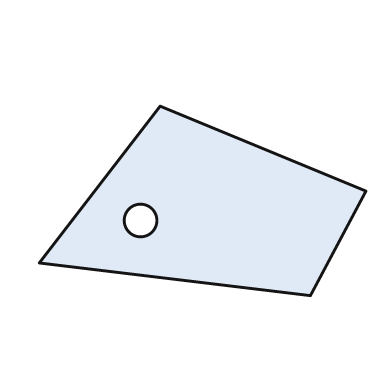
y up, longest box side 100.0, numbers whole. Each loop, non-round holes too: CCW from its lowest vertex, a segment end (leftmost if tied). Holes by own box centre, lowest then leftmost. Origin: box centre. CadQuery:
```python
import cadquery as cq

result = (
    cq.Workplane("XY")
    .moveTo(33.0, -29.0)
    .lineTo(50.0, 3.0)
    .lineTo(-13.0, 29.0)
    .lineTo(-50.0, -19.0)
    .close()
    .moveTo(-19.0, -6.0)
    .circle(5.0)
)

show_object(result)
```